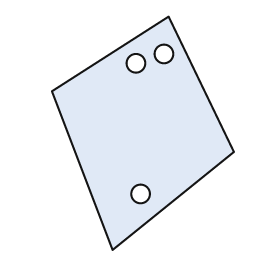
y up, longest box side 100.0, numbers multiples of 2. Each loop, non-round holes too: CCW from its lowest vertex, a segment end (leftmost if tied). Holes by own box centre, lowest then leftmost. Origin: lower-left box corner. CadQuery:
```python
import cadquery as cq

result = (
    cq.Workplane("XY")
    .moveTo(26.0, 0.0)
    .lineTo(78.0, 42.0)
    .lineTo(50.0, 100.0)
    .lineTo(0.0, 68.0)
    .close()
    .moveTo(38.0, 24.0)
    .circle(4.0)
    .moveTo(36.0, 80.0)
    .circle(4.0)
    .moveTo(48.0, 84.0)
    .circle(4.0)
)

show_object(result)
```